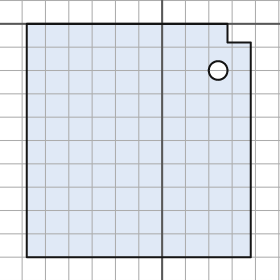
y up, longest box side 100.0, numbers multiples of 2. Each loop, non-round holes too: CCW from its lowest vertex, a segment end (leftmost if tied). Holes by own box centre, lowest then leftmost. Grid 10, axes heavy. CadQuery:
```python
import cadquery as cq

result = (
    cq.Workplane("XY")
    .moveTo(-58.0, -100.0)
    .lineTo(38.0, -100.0)
    .lineTo(38.0, -8.0)
    .lineTo(28.0, -8.0)
    .lineTo(28.0, 0.0)
    .lineTo(-58.0, 0.0)
    .close()
    .moveTo(24.0, -20.0)
    .circle(4.0)
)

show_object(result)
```